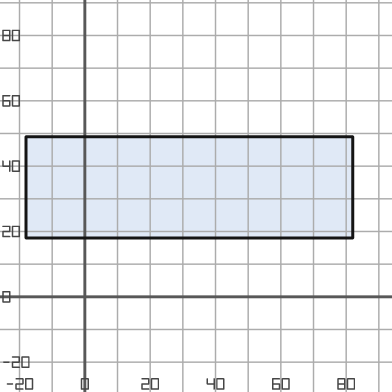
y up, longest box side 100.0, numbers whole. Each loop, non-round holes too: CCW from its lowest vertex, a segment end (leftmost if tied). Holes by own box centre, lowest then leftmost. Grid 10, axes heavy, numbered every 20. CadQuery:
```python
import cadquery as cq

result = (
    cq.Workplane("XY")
    .moveTo(-18.0, 18.0)
    .lineTo(82.0, 18.0)
    .lineTo(82.0, 49.0)
    .lineTo(-18.0, 49.0)
    .close()
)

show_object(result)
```